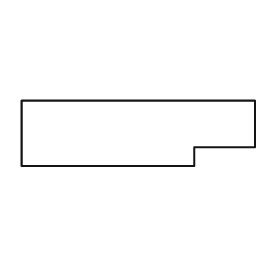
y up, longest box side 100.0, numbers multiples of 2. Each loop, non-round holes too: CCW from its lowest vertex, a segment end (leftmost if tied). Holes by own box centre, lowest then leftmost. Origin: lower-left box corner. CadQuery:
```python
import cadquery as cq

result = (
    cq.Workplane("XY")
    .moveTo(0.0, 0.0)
    .lineTo(74.0, 0.0)
    .lineTo(74.0, 8.0)
    .lineTo(100.0, 8.0)
    .lineTo(100.0, 28.0)
    .lineTo(0.0, 28.0)
    .close()
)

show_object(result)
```